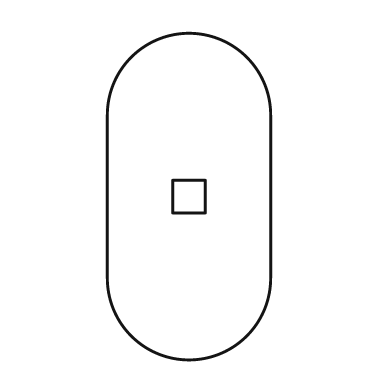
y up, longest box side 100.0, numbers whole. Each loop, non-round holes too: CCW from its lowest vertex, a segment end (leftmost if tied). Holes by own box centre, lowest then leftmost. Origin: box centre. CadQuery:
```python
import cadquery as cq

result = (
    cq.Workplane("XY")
    .moveTo(-25.0, -25.0)
    .threePointArc((0.0, -50.0), (25.0, -25.0))
    .lineTo(25.0, 25.0)
    .threePointArc((0.0, 50.0), (-25.0, 25.0))
    .close()
    .moveTo(-5.0, -5.0)
    .lineTo(5.0, -5.0)
    .lineTo(5.0, 5.0)
    .lineTo(-5.0, 5.0)
    .close()
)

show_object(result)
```